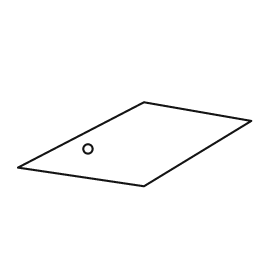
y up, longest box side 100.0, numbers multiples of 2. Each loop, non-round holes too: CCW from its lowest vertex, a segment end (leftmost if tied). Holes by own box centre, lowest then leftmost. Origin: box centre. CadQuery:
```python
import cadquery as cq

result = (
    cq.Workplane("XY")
    .moveTo(4.0, -18.0)
    .lineTo(50.0, 10.0)
    .lineTo(4.0, 18.0)
    .lineTo(-50.0, -10.0)
    .close()
    .moveTo(-20.0, -2.0)
    .circle(2.0)
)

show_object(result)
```